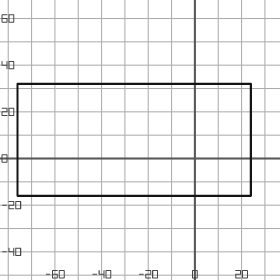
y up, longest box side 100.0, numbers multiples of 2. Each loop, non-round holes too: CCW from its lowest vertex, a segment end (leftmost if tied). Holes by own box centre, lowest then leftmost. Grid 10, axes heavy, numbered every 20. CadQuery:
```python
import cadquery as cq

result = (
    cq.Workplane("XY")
    .moveTo(-76.0, -16.0)
    .lineTo(24.0, -16.0)
    .lineTo(24.0, 32.0)
    .lineTo(-76.0, 32.0)
    .close()
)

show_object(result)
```